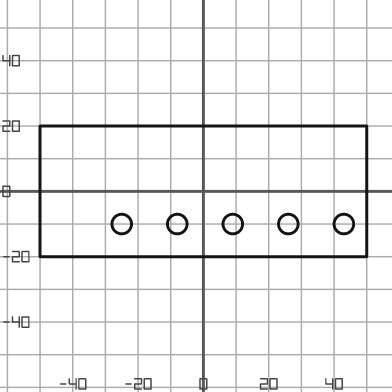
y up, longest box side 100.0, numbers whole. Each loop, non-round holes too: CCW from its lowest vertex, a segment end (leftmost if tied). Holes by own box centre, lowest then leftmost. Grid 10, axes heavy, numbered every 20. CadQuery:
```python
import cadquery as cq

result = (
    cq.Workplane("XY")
    .moveTo(-50.0, -20.0)
    .lineTo(50.0, -20.0)
    .lineTo(50.0, 20.0)
    .lineTo(-50.0, 20.0)
    .close()
    .moveTo(-25.0, -10.0)
    .circle(3.0)
    .moveTo(-8.0, -10.0)
    .circle(3.0)
    .moveTo(9.0, -10.0)
    .circle(3.0)
    .moveTo(26.0, -10.0)
    .circle(3.0)
    .moveTo(43.0, -10.0)
    .circle(3.0)
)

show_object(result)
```